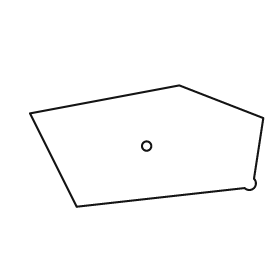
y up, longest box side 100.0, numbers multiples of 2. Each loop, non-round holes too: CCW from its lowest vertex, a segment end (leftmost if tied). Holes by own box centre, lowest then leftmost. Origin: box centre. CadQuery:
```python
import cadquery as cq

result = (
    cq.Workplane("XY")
    .moveTo(-30.0, -26.0)
    .lineTo(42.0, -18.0)
    .threePointArc((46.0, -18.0), (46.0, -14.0))
    .lineTo(50.0, 12.0)
    .lineTo(14.0, 26.0)
    .lineTo(-50.0, 14.0)
    .close()
    .moveTo(0.0, 0.0)
    .circle(2.0)
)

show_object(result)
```